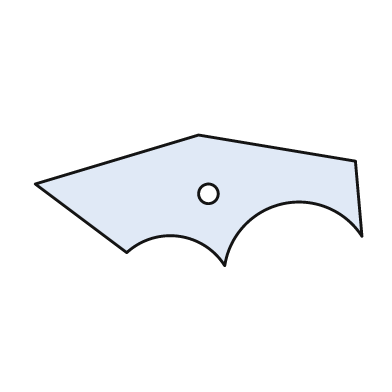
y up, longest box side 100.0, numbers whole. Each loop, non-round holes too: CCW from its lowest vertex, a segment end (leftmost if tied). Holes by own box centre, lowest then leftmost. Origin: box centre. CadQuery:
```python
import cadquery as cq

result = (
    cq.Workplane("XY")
    .moveTo(8.0, -20.0)
    .threePointArc((26.0, -1.0), (50.0, -11.0))
    .lineTo(48.0, 12.0)
    .lineTo(0.0, 20.0)
    .lineTo(-50.0, 5.0)
    .lineTo(-22.0, -16.0)
    .threePointArc((-6.0, -11.0), (8.0, -20.0))
    .close()
    .moveTo(3.0, 2.0)
    .circle(3.0)
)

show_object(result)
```